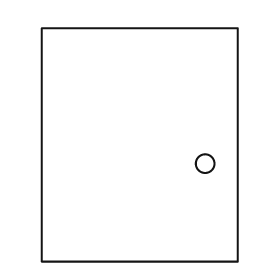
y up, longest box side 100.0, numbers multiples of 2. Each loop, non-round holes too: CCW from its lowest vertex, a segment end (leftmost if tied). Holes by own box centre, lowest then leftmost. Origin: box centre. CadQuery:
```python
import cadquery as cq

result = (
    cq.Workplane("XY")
    .moveTo(-42.0, -50.0)
    .lineTo(42.0, -50.0)
    .lineTo(42.0, 50.0)
    .lineTo(-42.0, 50.0)
    .close()
    .moveTo(28.0, -8.0)
    .circle(4.0)
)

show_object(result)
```